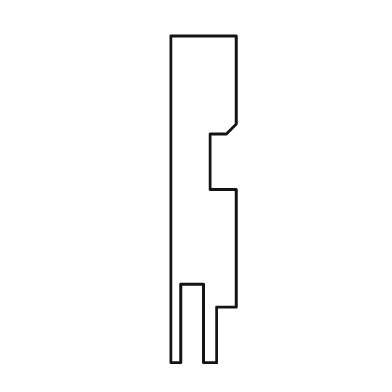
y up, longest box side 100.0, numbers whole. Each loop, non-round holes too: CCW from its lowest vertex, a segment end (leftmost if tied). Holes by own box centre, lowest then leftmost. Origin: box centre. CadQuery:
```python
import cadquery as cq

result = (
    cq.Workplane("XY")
    .moveTo(-10.0, -50.0)
    .lineTo(-7.0, -50.0)
    .lineTo(-7.0, -26.0)
    .lineTo(0.0, -26.0)
    .lineTo(0.0, -50.0)
    .lineTo(4.0, -50.0)
    .lineTo(4.0, -33.0)
    .lineTo(10.0, -33.0)
    .lineTo(10.0, 3.0)
    .lineTo(2.0, 3.0)
    .lineTo(2.0, 20.0)
    .lineTo(7.0, 20.0)
    .lineTo(10.0, 23.0)
    .lineTo(10.0, 50.0)
    .lineTo(-10.0, 50.0)
    .close()
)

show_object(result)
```